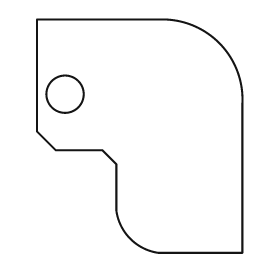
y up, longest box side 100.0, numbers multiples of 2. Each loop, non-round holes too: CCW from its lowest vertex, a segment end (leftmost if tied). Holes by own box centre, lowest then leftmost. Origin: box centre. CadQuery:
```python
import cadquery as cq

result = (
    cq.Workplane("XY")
    .moveTo(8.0, -50.0)
    .lineTo(44.0, -50.0)
    .lineTo(44.0, 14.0)
    .threePointArc((34.0, 40.0), (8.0, 50.0))
    .lineTo(-44.0, 50.0)
    .lineTo(-44.0, 2.0)
    .lineTo(-36.0, -6.0)
    .lineTo(-16.0, -6.0)
    .lineTo(-10.0, -12.0)
    .lineTo(-10.0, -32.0)
    .threePointArc((-4.0, -44.0), (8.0, -50.0))
    .close()
    .moveTo(-32.0, 18.0)
    .circle(8.0)
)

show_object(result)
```